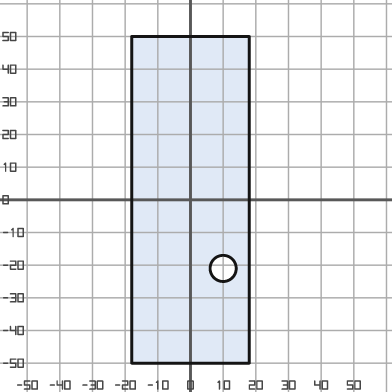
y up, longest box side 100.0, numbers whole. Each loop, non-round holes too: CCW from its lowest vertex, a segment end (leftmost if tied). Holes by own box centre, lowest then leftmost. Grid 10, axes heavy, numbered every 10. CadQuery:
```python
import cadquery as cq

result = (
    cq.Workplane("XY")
    .moveTo(-18.0, -50.0)
    .lineTo(18.0, -50.0)
    .lineTo(18.0, 50.0)
    .lineTo(-18.0, 50.0)
    .close()
    .moveTo(10.0, -21.0)
    .circle(4.0)
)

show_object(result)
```